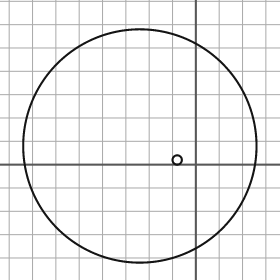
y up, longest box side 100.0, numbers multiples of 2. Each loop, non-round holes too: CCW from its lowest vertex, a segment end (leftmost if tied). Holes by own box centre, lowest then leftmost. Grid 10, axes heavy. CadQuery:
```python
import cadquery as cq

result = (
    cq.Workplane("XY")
    .moveTo(-24.0, 8.0)
    .circle(50.0)
    .moveTo(-8.0, 2.0)
    .circle(2.0)
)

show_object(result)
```